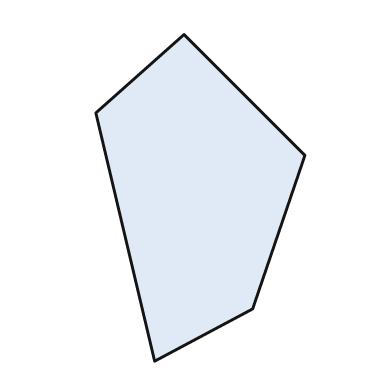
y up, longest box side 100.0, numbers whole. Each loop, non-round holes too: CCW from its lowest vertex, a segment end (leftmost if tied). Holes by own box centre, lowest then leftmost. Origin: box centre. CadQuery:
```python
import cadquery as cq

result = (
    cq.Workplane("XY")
    .moveTo(-14.0, -50.0)
    .lineTo(16.0, -34.0)
    .lineTo(32.0, 13.0)
    .lineTo(-5.0, 50.0)
    .lineTo(-32.0, 26.0)
    .close()
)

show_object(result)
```